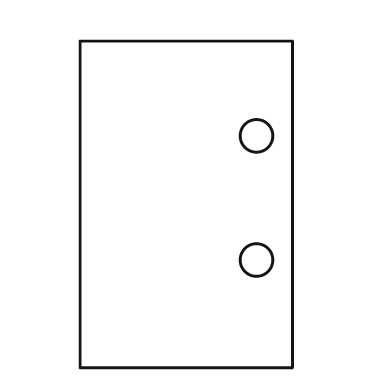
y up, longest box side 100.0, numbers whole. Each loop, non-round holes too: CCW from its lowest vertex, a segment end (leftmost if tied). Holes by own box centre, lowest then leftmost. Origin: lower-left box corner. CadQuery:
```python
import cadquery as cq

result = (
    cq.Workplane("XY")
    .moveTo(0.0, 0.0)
    .lineTo(65.0, 0.0)
    .lineTo(65.0, 100.0)
    .lineTo(0.0, 100.0)
    .close()
    .moveTo(54.0, 33.0)
    .circle(5.0)
    .moveTo(54.0, 71.0)
    .circle(5.0)
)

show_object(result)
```